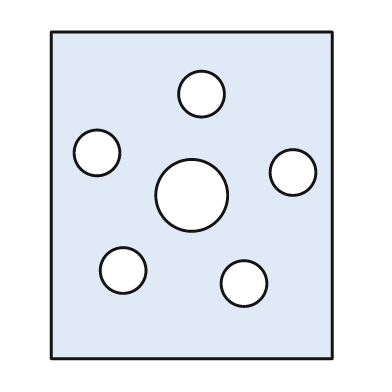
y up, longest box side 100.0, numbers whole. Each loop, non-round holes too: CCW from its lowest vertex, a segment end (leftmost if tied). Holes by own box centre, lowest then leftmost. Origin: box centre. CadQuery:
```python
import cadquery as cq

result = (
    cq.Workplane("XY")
    .moveTo(-43.0, -50.0)
    .lineTo(43.0, -50.0)
    .lineTo(43.0, 50.0)
    .lineTo(-43.0, 50.0)
    .close()
    .moveTo(16.0, -27.0)
    .circle(7.0)
    .moveTo(-21.0, -23.0)
    .circle(7.0)
    .moveTo(0.0, 0.0)
    .circle(11.0)
    .moveTo(31.0, 7.0)
    .circle(7.0)
    .moveTo(-29.0, 13.0)
    .circle(7.0)
    .moveTo(3.0, 31.0)
    .circle(7.0)
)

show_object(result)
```